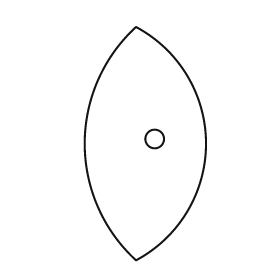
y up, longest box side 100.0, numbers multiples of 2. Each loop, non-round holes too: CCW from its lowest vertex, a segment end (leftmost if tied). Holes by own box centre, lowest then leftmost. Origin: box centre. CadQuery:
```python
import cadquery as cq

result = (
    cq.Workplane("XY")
    .moveTo(-4.0, -50.0)
    .threePointArc((26.0, 0.0), (-4.0, 50.0))
    .threePointArc((-26.0, 0.0), (-4.0, -50.0))
    .close()
    .moveTo(4.0, 2.0)
    .circle(4.0)
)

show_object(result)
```